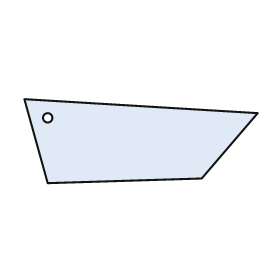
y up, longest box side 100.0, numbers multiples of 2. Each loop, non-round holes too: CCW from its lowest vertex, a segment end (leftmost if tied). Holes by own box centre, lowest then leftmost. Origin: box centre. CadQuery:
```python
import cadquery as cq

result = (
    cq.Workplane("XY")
    .moveTo(-40.0, -18.0)
    .lineTo(26.0, -16.0)
    .lineTo(50.0, 12.0)
    .lineTo(-50.0, 18.0)
    .close()
    .moveTo(-40.0, 10.0)
    .circle(2.0)
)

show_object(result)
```